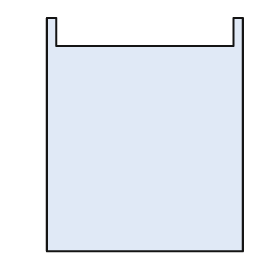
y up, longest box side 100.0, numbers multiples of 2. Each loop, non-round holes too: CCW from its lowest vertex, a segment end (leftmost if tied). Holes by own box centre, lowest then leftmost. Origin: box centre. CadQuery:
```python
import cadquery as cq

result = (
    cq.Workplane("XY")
    .moveTo(-42.0, -50.0)
    .lineTo(42.0, -50.0)
    .lineTo(42.0, 50.0)
    .lineTo(38.0, 50.0)
    .lineTo(38.0, 38.0)
    .lineTo(-38.0, 38.0)
    .lineTo(-38.0, 50.0)
    .lineTo(-42.0, 50.0)
    .close()
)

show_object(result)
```